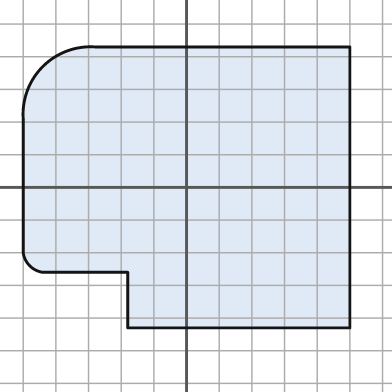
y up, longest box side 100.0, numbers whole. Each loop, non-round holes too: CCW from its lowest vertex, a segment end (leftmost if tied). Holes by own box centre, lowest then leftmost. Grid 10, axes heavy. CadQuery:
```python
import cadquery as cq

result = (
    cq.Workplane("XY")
    .moveTo(-18.0, -43.0)
    .lineTo(50.0, -43.0)
    .lineTo(50.0, 43.0)
    .lineTo(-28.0, 43.0)
    .threePointArc((-44.0, 37.0), (-50.0, 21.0))
    .lineTo(-50.0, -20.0)
    .threePointArc((-48.0, -24.0), (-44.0, -26.0))
    .lineTo(-18.0, -26.0)
    .close()
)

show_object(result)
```